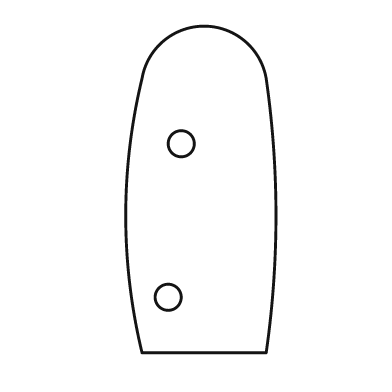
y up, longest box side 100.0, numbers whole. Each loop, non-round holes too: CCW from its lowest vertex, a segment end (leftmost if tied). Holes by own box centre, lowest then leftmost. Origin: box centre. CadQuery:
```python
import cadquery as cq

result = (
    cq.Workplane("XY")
    .moveTo(-18.0, -50.0)
    .lineTo(20.0, -50.0)
    .threePointArc((23.0, -8.0), (20.0, 34.0))
    .threePointArc((1.0, 50.0), (-18.0, 34.0))
    .threePointArc((-23.0, -8.0), (-18.0, -50.0))
    .close()
    .moveTo(-10.0, -33.0)
    .circle(4.0)
    .moveTo(-6.0, 14.0)
    .circle(4.0)
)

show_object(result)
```